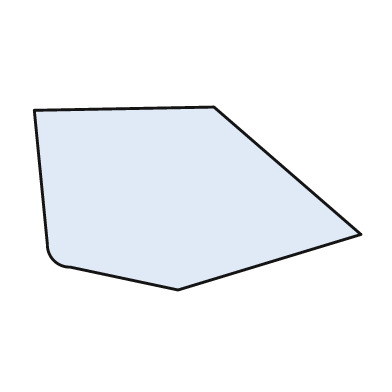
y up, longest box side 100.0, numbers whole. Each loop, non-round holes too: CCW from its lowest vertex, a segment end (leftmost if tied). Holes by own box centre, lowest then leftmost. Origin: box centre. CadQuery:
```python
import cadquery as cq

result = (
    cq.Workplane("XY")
    .moveTo(-6.0, -28.0)
    .lineTo(50.0, -11.0)
    .lineTo(5.0, 28.0)
    .lineTo(-50.0, 27.0)
    .lineTo(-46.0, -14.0)
    .threePointArc((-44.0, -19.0), (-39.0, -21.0))
    .close()
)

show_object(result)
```